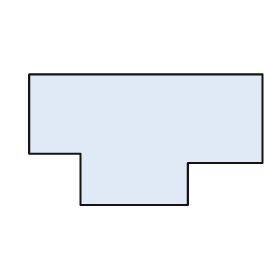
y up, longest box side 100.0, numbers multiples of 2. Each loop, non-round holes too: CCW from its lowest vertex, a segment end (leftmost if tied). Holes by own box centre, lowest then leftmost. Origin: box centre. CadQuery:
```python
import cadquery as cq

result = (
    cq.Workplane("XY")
    .moveTo(-28.0, -28.0)
    .lineTo(18.0, -28.0)
    .lineTo(18.0, -10.0)
    .lineTo(50.0, -10.0)
    .lineTo(50.0, 28.0)
    .lineTo(-50.0, 28.0)
    .lineTo(-50.0, -6.0)
    .lineTo(-28.0, -6.0)
    .close()
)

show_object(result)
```